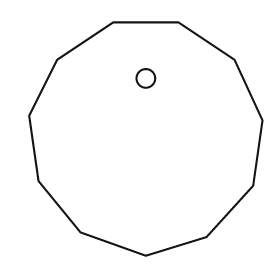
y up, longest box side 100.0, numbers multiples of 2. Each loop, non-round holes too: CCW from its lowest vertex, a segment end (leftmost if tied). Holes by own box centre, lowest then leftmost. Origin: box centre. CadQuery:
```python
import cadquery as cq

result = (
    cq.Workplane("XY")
    .moveTo(0.0, -50.0)
    .lineTo(26.0, -42.0)
    .lineTo(46.0, -20.0)
    .lineTo(50.0, 8.0)
    .lineTo(38.0, 34.0)
    .lineTo(14.0, 50.0)
    .lineTo(-14.0, 50.0)
    .lineTo(-38.0, 34.0)
    .lineTo(-50.0, 10.0)
    .lineTo(-46.0, -18.0)
    .lineTo(-28.0, -40.0)
    .close()
    .moveTo(0.0, 26.0)
    .circle(4.0)
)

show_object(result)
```